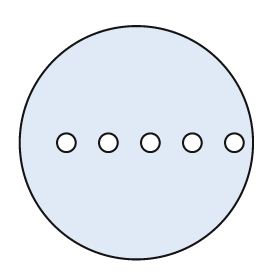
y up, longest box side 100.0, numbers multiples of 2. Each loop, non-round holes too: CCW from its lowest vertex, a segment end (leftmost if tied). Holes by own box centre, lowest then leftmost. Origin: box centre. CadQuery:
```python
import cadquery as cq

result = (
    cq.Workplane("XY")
    .moveTo(0.0, 0.0)
    .circle(50.0)
    .moveTo(-30.0, 0.0)
    .circle(4.0)
    .moveTo(-12.0, 0.0)
    .circle(4.0)
    .moveTo(6.0, 0.0)
    .circle(4.0)
    .moveTo(24.0, 0.0)
    .circle(4.0)
    .moveTo(42.0, 0.0)
    .circle(4.0)
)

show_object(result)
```